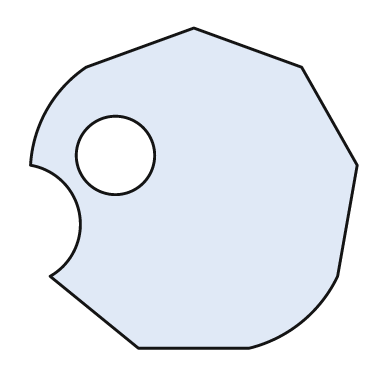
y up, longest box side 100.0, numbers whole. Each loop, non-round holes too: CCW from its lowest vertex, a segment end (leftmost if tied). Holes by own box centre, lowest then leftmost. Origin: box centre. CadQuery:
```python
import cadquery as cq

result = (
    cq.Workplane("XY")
    .moveTo(-17.0, -49.0)
    .lineTo(17.0, -49.0)
    .threePointArc((33.0, -41.0), (44.0, -27.0))
    .lineTo(50.0, 7.0)
    .lineTo(33.0, 37.0)
    .lineTo(0.0, 49.0)
    .lineTo(-33.0, 37.0)
    .threePointArc((-45.0, 24.0), (-50.0, 7.0))
    .threePointArc((-35.0, -8.0), (-44.0, -27.0))
    .close()
    .moveTo(-24.0, 10.0)
    .circle(12.0)
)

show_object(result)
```